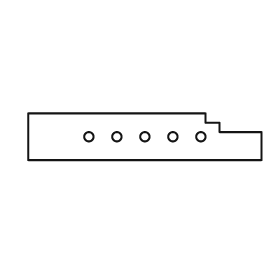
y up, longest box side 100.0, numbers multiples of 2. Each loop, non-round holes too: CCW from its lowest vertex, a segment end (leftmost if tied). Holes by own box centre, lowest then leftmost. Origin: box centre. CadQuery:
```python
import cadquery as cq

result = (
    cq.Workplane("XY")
    .moveTo(-50.0, -10.0)
    .lineTo(50.0, -10.0)
    .lineTo(50.0, 2.0)
    .lineTo(32.0, 2.0)
    .lineTo(32.0, 6.0)
    .lineTo(26.0, 6.0)
    .lineTo(26.0, 10.0)
    .lineTo(-50.0, 10.0)
    .close()
    .moveTo(-24.0, 0.0)
    .circle(2.0)
    .moveTo(-12.0, 0.0)
    .circle(2.0)
    .moveTo(0.0, 0.0)
    .circle(2.0)
    .moveTo(12.0, 0.0)
    .circle(2.0)
    .moveTo(24.0, 0.0)
    .circle(2.0)
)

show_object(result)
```